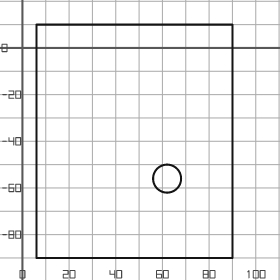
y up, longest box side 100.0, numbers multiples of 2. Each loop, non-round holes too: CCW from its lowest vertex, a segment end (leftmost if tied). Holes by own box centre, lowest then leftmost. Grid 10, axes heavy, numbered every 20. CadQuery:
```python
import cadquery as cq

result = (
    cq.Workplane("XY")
    .moveTo(6.0, -90.0)
    .lineTo(90.0, -90.0)
    .lineTo(90.0, 10.0)
    .lineTo(6.0, 10.0)
    .close()
    .moveTo(62.0, -56.0)
    .circle(6.0)
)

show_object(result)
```